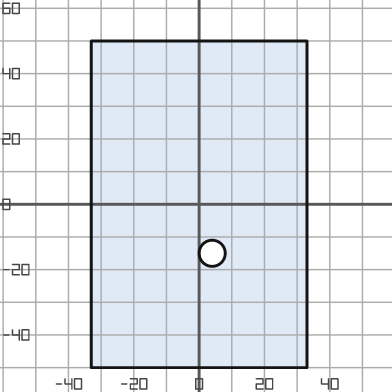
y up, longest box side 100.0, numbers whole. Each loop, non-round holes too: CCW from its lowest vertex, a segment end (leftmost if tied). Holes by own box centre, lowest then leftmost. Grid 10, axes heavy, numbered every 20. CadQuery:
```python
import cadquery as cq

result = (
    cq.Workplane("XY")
    .moveTo(-33.0, -50.0)
    .lineTo(33.0, -50.0)
    .lineTo(33.0, 50.0)
    .lineTo(-33.0, 50.0)
    .close()
    .moveTo(4.0, -15.0)
    .circle(4.0)
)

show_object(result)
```